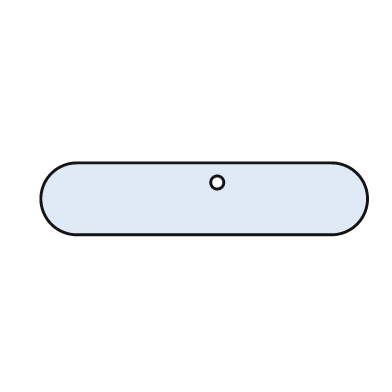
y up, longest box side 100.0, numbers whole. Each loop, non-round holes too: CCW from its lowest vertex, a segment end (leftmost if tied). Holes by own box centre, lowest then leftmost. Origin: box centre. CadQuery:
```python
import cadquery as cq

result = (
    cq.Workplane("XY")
    .moveTo(-39.0, -11.0)
    .lineTo(39.0, -11.0)
    .threePointArc((50.0, 0.0), (39.0, 11.0))
    .lineTo(-39.0, 11.0)
    .threePointArc((-50.0, 0.0), (-39.0, -11.0))
    .close()
    .moveTo(4.0, 5.0)
    .circle(2.0)
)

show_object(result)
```